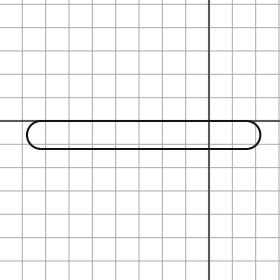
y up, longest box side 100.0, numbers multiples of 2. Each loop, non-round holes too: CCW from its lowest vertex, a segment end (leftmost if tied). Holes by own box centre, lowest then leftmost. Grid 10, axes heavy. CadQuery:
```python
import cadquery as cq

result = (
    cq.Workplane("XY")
    .moveTo(-72.0, -12.0)
    .lineTo(16.0, -12.0)
    .threePointArc((22.0, -6.0), (16.0, 0.0))
    .lineTo(-72.0, 0.0)
    .threePointArc((-78.0, -6.0), (-72.0, -12.0))
    .close()
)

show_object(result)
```